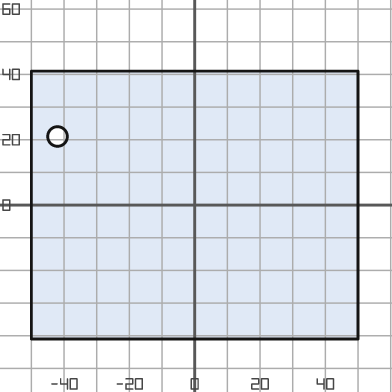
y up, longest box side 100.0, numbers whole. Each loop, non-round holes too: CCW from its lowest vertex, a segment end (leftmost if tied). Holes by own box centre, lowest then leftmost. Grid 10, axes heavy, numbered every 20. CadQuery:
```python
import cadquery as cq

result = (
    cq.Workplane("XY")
    .moveTo(-50.0, -41.0)
    .lineTo(50.0, -41.0)
    .lineTo(50.0, 41.0)
    .lineTo(-50.0, 41.0)
    .close()
    .moveTo(-42.0, 21.0)
    .circle(3.0)
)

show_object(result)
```